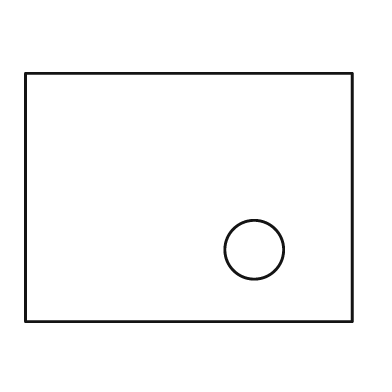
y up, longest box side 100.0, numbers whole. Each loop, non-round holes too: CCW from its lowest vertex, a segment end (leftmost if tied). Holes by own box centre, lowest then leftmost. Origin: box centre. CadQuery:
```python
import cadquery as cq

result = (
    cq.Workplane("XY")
    .moveTo(-50.0, -38.0)
    .lineTo(50.0, -38.0)
    .lineTo(50.0, 38.0)
    .lineTo(-50.0, 38.0)
    .close()
    .moveTo(20.0, -16.0)
    .circle(9.0)
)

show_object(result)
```